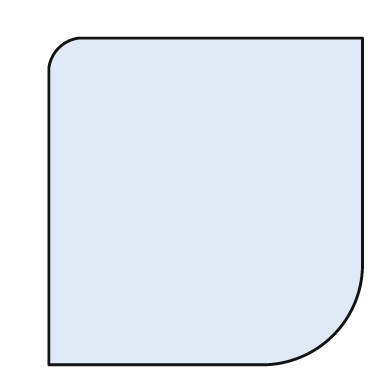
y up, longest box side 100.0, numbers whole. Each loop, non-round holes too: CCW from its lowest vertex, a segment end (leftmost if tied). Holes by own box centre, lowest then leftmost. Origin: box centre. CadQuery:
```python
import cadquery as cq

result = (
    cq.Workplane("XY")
    .moveTo(-48.0, -50.0)
    .lineTo(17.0, -50.0)
    .threePointArc((39.0, -41.0), (48.0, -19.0))
    .lineTo(48.0, 50.0)
    .lineTo(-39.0, 50.0)
    .threePointArc((-45.0, 47.0), (-48.0, 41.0))
    .close()
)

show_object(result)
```